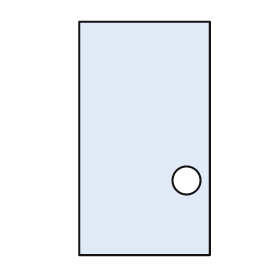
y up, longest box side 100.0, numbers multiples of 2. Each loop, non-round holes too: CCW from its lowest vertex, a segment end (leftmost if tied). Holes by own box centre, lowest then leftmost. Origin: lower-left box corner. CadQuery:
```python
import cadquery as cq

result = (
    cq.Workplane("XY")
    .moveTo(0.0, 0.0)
    .lineTo(56.0, 0.0)
    .lineTo(56.0, 100.0)
    .lineTo(0.0, 100.0)
    .close()
    .moveTo(46.0, 32.0)
    .circle(6.0)
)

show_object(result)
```